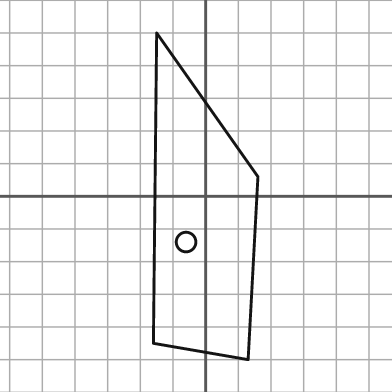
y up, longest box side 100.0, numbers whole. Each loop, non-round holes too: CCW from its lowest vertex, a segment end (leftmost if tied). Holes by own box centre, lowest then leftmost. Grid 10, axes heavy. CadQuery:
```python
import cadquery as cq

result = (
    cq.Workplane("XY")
    .moveTo(13.0, -50.0)
    .lineTo(16.0, 6.0)
    .lineTo(-15.0, 50.0)
    .lineTo(-16.0, -45.0)
    .close()
    .moveTo(-6.0, -14.0)
    .circle(3.0)
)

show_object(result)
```